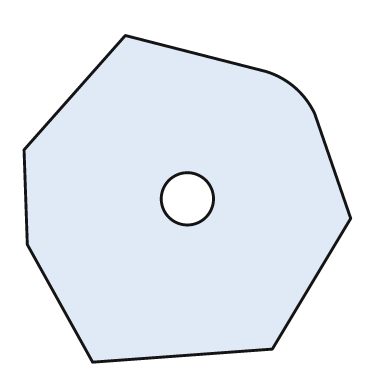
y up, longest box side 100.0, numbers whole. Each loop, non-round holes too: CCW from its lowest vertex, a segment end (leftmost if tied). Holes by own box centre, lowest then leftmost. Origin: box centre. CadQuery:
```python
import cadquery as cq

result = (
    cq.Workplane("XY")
    .moveTo(-29.0, -50.0)
    .lineTo(26.0, -46.0)
    .lineTo(50.0, -6.0)
    .lineTo(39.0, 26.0)
    .threePointArc((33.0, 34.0), (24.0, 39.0))
    .lineTo(-19.0, 50.0)
    .lineTo(-50.0, 15.0)
    .lineTo(-49.0, -14.0)
    .close()
    .moveTo(0.0, 0.0)
    .circle(8.0)
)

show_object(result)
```